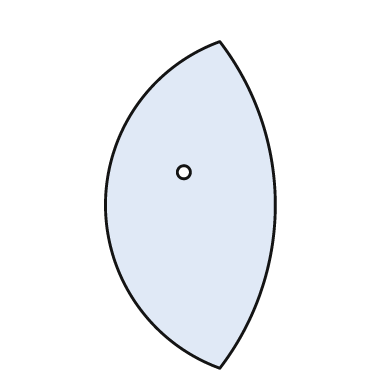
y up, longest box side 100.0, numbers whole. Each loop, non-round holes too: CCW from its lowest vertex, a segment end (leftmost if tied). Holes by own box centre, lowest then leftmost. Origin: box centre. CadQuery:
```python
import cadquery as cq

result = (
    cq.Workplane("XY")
    .moveTo(9.0, -50.0)
    .threePointArc((26.0, 0.0), (9.0, 50.0))
    .threePointArc((-26.0, 0.0), (9.0, -50.0))
    .close()
    .moveTo(-2.0, 10.0)
    .circle(2.0)
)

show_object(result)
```